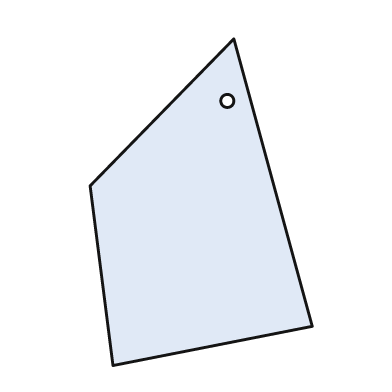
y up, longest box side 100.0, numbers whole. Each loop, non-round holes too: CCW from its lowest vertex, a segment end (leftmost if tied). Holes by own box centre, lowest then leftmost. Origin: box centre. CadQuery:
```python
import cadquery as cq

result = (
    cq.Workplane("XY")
    .moveTo(-27.0, -50.0)
    .lineTo(34.0, -38.0)
    .lineTo(10.0, 50.0)
    .lineTo(-34.0, 5.0)
    .close()
    .moveTo(8.0, 31.0)
    .circle(2.0)
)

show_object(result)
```